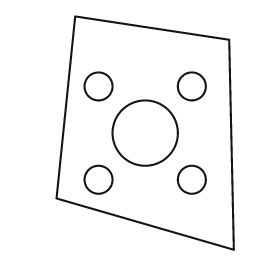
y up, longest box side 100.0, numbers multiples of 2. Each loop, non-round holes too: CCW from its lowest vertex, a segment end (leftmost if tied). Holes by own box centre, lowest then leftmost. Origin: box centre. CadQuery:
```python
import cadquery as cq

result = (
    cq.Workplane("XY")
    .moveTo(38.0, -50.0)
    .lineTo(36.0, 40.0)
    .lineTo(-30.0, 50.0)
    .lineTo(-38.0, -28.0)
    .close()
    .moveTo(-20.0, -20.0)
    .circle(6.0)
    .moveTo(20.0, -20.0)
    .circle(6.0)
    .moveTo(0.0, 0.0)
    .circle(14.0)
    .moveTo(-20.0, 20.0)
    .circle(6.0)
    .moveTo(20.0, 20.0)
    .circle(6.0)
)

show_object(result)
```